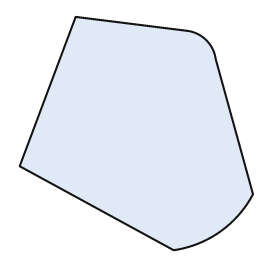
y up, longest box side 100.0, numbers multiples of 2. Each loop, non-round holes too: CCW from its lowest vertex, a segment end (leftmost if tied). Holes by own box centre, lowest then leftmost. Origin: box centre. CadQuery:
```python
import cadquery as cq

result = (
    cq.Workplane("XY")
    .moveTo(16.0, -50.0)
    .threePointArc((36.0, -42.0), (50.0, -26.0))
    .lineTo(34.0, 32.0)
    .threePointArc((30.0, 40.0), (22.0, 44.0))
    .lineTo(-26.0, 50.0)
    .lineTo(-50.0, -14.0)
    .close()
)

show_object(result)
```